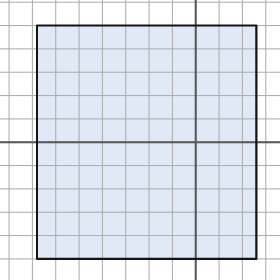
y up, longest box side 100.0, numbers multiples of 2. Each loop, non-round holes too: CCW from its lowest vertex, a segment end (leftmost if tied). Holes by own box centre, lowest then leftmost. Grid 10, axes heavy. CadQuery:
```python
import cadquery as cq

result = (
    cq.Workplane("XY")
    .moveTo(-68.0, -50.0)
    .lineTo(26.0, -50.0)
    .lineTo(26.0, 50.0)
    .lineTo(-68.0, 50.0)
    .close()
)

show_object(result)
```